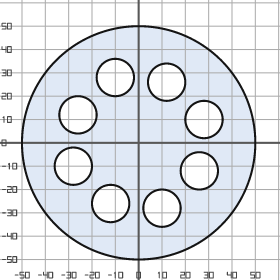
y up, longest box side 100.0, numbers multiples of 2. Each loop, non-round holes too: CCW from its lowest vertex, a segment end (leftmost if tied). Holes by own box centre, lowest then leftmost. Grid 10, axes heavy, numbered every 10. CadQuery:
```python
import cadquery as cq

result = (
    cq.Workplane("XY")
    .moveTo(0.0, 0.0)
    .circle(50.0)
    .moveTo(10.0, -28.0)
    .circle(8.0)
    .moveTo(-12.0, -26.0)
    .circle(8.0)
    .moveTo(26.0, -12.0)
    .circle(8.0)
    .moveTo(-28.0, -10.0)
    .circle(8.0)
    .moveTo(28.0, 10.0)
    .circle(8.0)
    .moveTo(-26.0, 12.0)
    .circle(8.0)
    .moveTo(12.0, 26.0)
    .circle(8.0)
    .moveTo(-10.0, 28.0)
    .circle(8.0)
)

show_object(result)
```